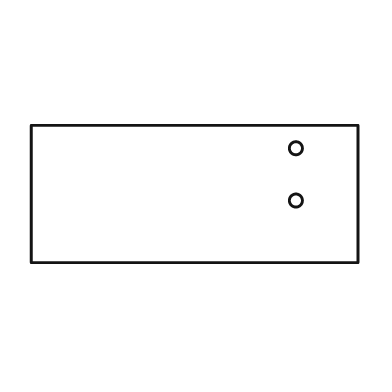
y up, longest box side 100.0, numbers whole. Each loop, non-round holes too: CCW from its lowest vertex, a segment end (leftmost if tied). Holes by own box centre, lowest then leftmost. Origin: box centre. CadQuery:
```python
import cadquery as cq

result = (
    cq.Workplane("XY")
    .moveTo(-50.0, -21.0)
    .lineTo(50.0, -21.0)
    .lineTo(50.0, 21.0)
    .lineTo(-50.0, 21.0)
    .close()
    .moveTo(31.0, -2.0)
    .circle(2.0)
    .moveTo(31.0, 14.0)
    .circle(2.0)
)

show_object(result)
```